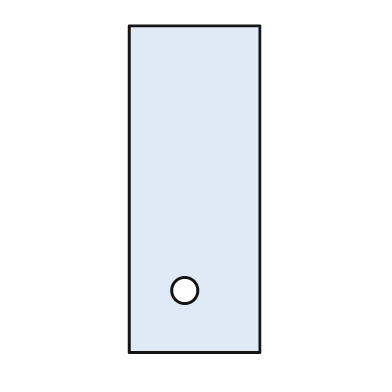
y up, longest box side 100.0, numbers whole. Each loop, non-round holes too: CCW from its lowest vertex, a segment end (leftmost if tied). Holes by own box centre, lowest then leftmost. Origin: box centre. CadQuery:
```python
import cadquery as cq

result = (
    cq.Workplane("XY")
    .moveTo(-20.0, -50.0)
    .lineTo(20.0, -50.0)
    .lineTo(20.0, 50.0)
    .lineTo(-20.0, 50.0)
    .close()
    .moveTo(-3.0, -31.0)
    .circle(4.0)
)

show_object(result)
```